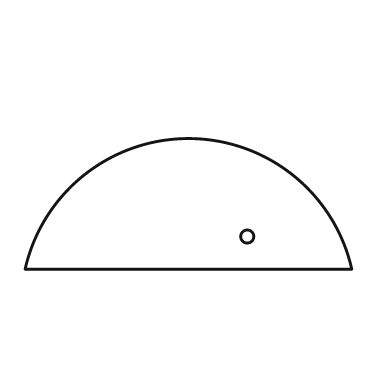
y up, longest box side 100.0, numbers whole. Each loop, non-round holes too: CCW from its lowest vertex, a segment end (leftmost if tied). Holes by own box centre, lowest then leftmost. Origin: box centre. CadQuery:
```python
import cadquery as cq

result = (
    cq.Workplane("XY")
    .moveTo(-50.0, -20.0)
    .lineTo(50.0, -20.0)
    .threePointArc((0.0, 20.0), (-50.0, -20.0))
    .close()
    .moveTo(18.0, -10.0)
    .circle(2.0)
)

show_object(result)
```